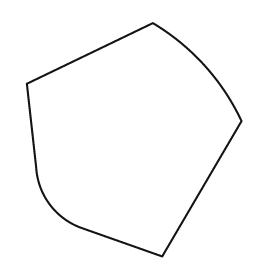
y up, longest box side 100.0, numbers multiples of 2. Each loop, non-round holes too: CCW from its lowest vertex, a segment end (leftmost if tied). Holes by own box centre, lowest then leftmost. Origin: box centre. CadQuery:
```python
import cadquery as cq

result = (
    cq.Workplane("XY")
    .moveTo(12.0, -50.0)
    .lineTo(46.0, 8.0)
    .threePointArc((30.0, 32.0), (8.0, 50.0))
    .lineTo(-46.0, 24.0)
    .lineTo(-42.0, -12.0)
    .threePointArc((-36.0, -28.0), (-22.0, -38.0))
    .close()
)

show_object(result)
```